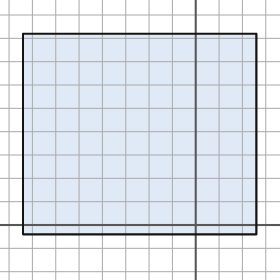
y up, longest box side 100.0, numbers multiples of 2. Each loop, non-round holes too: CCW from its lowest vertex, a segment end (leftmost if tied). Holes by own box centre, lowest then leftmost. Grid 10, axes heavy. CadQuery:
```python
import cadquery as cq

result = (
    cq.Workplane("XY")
    .moveTo(-74.0, -4.0)
    .lineTo(26.0, -4.0)
    .lineTo(26.0, 82.0)
    .lineTo(-74.0, 82.0)
    .close()
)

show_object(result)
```